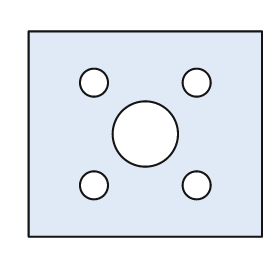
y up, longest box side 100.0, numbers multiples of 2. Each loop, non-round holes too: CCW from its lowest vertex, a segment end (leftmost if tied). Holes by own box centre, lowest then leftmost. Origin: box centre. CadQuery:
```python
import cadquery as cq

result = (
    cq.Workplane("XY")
    .moveTo(-50.0, -44.0)
    .lineTo(50.0, -44.0)
    .lineTo(50.0, 44.0)
    .lineTo(-50.0, 44.0)
    .close()
    .moveTo(-22.0, -22.0)
    .circle(6.0)
    .moveTo(22.0, -22.0)
    .circle(6.0)
    .moveTo(0.0, 0.0)
    .circle(14.0)
    .moveTo(-22.0, 22.0)
    .circle(6.0)
    .moveTo(22.0, 22.0)
    .circle(6.0)
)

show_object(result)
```